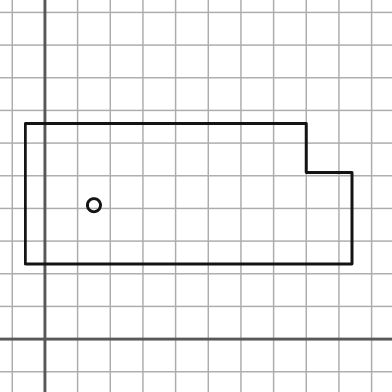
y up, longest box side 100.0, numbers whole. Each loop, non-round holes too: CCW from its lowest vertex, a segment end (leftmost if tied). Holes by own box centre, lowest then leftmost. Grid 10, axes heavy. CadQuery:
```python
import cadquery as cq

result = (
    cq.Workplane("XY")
    .moveTo(-6.0, 23.0)
    .lineTo(94.0, 23.0)
    .lineTo(94.0, 51.0)
    .lineTo(80.0, 51.0)
    .lineTo(80.0, 66.0)
    .lineTo(-6.0, 66.0)
    .close()
    .moveTo(15.0, 41.0)
    .circle(2.0)
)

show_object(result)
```